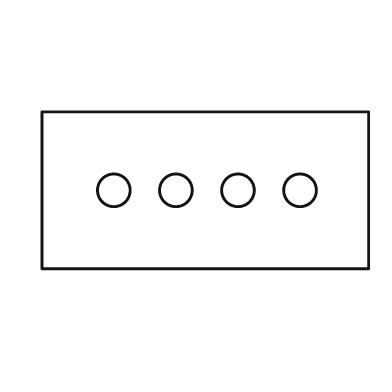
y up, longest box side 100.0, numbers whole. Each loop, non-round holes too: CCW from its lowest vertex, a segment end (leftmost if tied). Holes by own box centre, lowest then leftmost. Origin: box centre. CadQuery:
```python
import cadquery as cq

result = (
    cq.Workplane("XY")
    .moveTo(-50.0, -24.0)
    .lineTo(50.0, -24.0)
    .lineTo(50.0, 24.0)
    .lineTo(-50.0, 24.0)
    .close()
    .moveTo(-28.0, 0.0)
    .circle(5.0)
    .moveTo(-9.0, 0.0)
    .circle(5.0)
    .moveTo(10.0, 0.0)
    .circle(5.0)
    .moveTo(29.0, 0.0)
    .circle(5.0)
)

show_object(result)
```